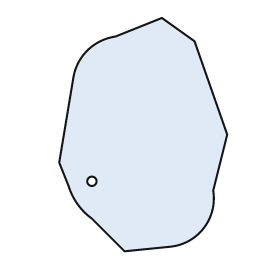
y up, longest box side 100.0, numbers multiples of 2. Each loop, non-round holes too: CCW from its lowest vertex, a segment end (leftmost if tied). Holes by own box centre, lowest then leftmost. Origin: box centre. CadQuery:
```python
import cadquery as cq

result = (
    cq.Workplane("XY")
    .moveTo(-8.0, -50.0)
    .lineTo(12.0, -48.0)
    .threePointArc((26.0, -40.0), (30.0, -24.0))
    .lineTo(36.0, 0.0)
    .lineTo(22.0, 40.0)
    .lineTo(8.0, 50.0)
    .lineTo(-12.0, 42.0)
    .threePointArc((-24.0, 36.0), (-30.0, 24.0))
    .lineTo(-36.0, -12.0)
    .lineTo(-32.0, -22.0)
    .threePointArc((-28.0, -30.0), (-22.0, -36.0))
    .close()
    .moveTo(-22.0, -20.0)
    .circle(2.0)
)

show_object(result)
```